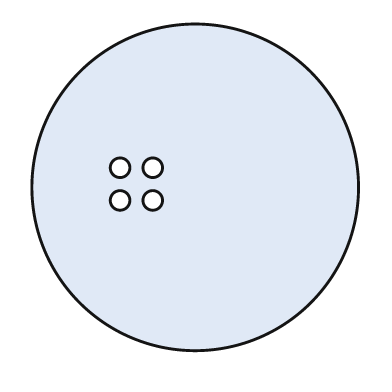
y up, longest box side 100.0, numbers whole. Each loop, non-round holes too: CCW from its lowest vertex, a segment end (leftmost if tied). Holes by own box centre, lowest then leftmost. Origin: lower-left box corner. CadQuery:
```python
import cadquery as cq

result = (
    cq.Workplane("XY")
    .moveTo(50.0, 50.0)
    .circle(50.0)
    .moveTo(27.0, 46.0)
    .circle(3.0)
    .moveTo(37.0, 46.0)
    .circle(3.0)
    .moveTo(27.0, 56.0)
    .circle(3.0)
    .moveTo(37.0, 56.0)
    .circle(3.0)
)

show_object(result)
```